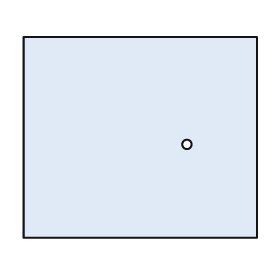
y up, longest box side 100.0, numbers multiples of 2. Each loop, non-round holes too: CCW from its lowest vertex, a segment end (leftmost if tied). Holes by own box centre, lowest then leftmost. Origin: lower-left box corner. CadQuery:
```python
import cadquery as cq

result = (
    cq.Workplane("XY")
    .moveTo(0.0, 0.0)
    .lineTo(100.0, 0.0)
    .lineTo(100.0, 86.0)
    .lineTo(0.0, 86.0)
    .close()
    .moveTo(70.0, 40.0)
    .circle(2.0)
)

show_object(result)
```